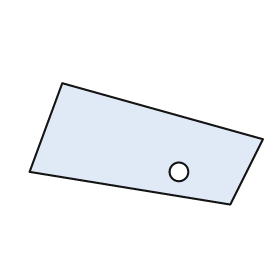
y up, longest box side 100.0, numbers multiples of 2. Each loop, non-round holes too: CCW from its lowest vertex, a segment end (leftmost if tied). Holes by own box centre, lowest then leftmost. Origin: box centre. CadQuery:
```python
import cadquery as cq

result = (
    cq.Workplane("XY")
    .moveTo(36.0, -26.0)
    .lineTo(50.0, 2.0)
    .lineTo(-36.0, 26.0)
    .lineTo(-50.0, -12.0)
    .close()
    .moveTo(14.0, -12.0)
    .circle(4.0)
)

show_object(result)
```